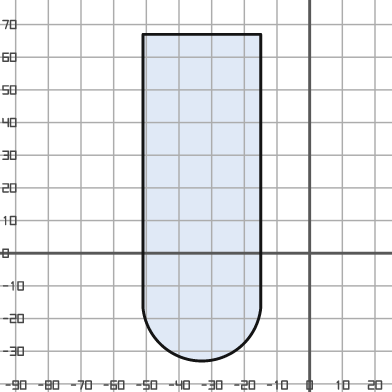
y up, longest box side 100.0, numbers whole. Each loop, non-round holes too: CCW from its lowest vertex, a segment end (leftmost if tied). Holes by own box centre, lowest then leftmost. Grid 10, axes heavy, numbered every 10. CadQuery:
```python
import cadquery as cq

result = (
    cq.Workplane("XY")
    .moveTo(-51.0, -17.0)
    .threePointArc((-33.0, -33.0), (-15.0, -17.0))
    .lineTo(-15.0, 67.0)
    .lineTo(-51.0, 67.0)
    .close()
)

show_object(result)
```